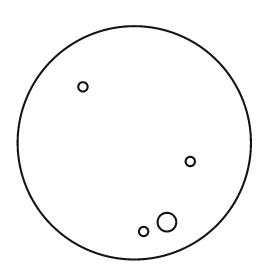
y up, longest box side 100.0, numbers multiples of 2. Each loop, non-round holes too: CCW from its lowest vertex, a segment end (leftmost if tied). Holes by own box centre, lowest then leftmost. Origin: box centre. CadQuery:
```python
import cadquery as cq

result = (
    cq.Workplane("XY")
    .moveTo(0.0, 0.0)
    .circle(50.0)
    .moveTo(4.0, -38.0)
    .circle(2.0)
    .moveTo(14.0, -34.0)
    .circle(4.0)
    .moveTo(24.0, -8.0)
    .circle(2.0)
    .moveTo(-22.0, 24.0)
    .circle(2.0)
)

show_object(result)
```